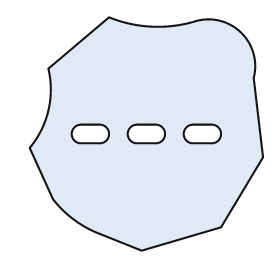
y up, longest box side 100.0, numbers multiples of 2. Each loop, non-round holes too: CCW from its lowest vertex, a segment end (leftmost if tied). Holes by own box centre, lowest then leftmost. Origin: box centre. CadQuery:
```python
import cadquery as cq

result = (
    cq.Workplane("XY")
    .moveTo(-2.0, -50.0)
    .lineTo(32.0, -40.0)
    .lineTo(50.0, -10.0)
    .lineTo(46.0, 24.0)
    .threePointArc((40.0, 44.0), (20.0, 48.0))
    .threePointArc((2.0, 46.0), (-16.0, 50.0))
    .lineTo(-42.0, 28.0)
    .threePointArc((-42.0, 10.0), (-50.0, -6.0))
    .lineTo(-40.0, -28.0)
    .threePointArc((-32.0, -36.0), (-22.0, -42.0))
    .close()
    .moveTo(-28.0, -4.0)
    .lineTo(-20.0, -4.0)
    .threePointArc((-16.0, 0.0), (-20.0, 4.0))
    .lineTo(-28.0, 4.0)
    .threePointArc((-32.0, 0.0), (-28.0, -4.0))
    .close()
    .moveTo(-4.0, -4.0)
    .lineTo(4.0, -4.0)
    .threePointArc((8.0, 0.0), (4.0, 4.0))
    .lineTo(-4.0, 4.0)
    .threePointArc((-8.0, 0.0), (-4.0, -4.0))
    .close()
    .moveTo(20.0, -4.0)
    .lineTo(28.0, -4.0)
    .threePointArc((32.0, 0.0), (28.0, 4.0))
    .lineTo(20.0, 4.0)
    .threePointArc((16.0, 0.0), (20.0, -4.0))
    .close()
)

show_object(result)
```